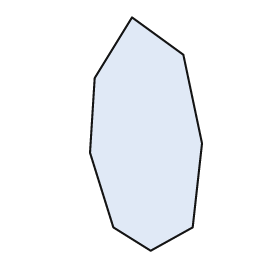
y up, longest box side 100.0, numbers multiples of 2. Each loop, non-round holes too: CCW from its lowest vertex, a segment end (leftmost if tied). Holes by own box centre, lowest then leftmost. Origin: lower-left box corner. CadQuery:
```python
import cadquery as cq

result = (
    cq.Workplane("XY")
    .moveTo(26.0, 0.0)
    .lineTo(44.0, 10.0)
    .lineTo(48.0, 46.0)
    .lineTo(40.0, 84.0)
    .lineTo(18.0, 100.0)
    .lineTo(2.0, 74.0)
    .lineTo(0.0, 42.0)
    .lineTo(10.0, 10.0)
    .close()
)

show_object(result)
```